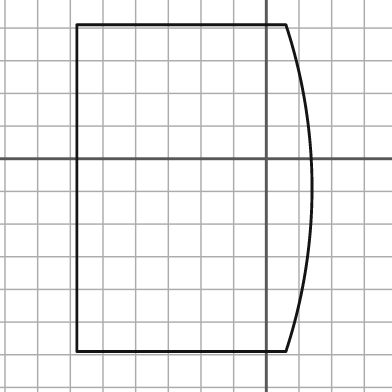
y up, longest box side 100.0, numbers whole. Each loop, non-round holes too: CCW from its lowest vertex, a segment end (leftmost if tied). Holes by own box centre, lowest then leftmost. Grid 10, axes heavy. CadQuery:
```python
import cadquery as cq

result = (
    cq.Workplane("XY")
    .moveTo(-58.0, -59.0)
    .lineTo(6.0, -59.0)
    .threePointArc((14.0, -9.0), (6.0, 41.0))
    .lineTo(-58.0, 41.0)
    .close()
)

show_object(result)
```